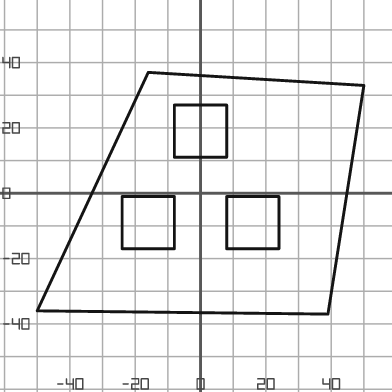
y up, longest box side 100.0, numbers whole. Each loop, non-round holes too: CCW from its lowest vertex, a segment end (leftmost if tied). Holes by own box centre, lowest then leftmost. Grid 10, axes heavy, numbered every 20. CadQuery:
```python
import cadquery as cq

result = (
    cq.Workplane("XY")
    .moveTo(39.0, -37.0)
    .lineTo(50.0, 33.0)
    .lineTo(-16.0, 37.0)
    .lineTo(-50.0, -36.0)
    .close()
    .moveTo(-24.0, -17.0)
    .lineTo(-8.0, -17.0)
    .lineTo(-8.0, -1.0)
    .lineTo(-24.0, -1.0)
    .close()
    .moveTo(8.0, -17.0)
    .lineTo(24.0, -17.0)
    .lineTo(24.0, -1.0)
    .lineTo(8.0, -1.0)
    .close()
    .moveTo(-8.0, 11.0)
    .lineTo(8.0, 11.0)
    .lineTo(8.0, 27.0)
    .lineTo(-8.0, 27.0)
    .close()
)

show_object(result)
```